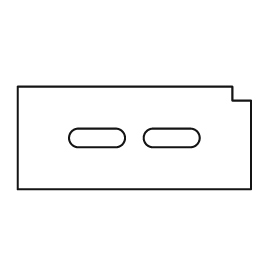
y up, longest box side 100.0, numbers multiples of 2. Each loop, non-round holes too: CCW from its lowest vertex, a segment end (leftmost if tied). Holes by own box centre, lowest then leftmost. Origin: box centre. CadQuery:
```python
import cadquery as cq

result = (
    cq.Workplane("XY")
    .moveTo(-50.0, -22.0)
    .lineTo(50.0, -22.0)
    .lineTo(50.0, 16.0)
    .lineTo(42.0, 16.0)
    .lineTo(42.0, 22.0)
    .lineTo(-50.0, 22.0)
    .close()
    .moveTo(-24.0, -4.0)
    .lineTo(-8.0, -4.0)
    .threePointArc((-4.0, 0.0), (-8.0, 4.0))
    .lineTo(-24.0, 4.0)
    .threePointArc((-28.0, 0.0), (-24.0, -4.0))
    .close()
    .moveTo(8.0, -4.0)
    .lineTo(24.0, -4.0)
    .threePointArc((28.0, 0.0), (24.0, 4.0))
    .lineTo(8.0, 4.0)
    .threePointArc((4.0, 0.0), (8.0, -4.0))
    .close()
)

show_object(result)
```